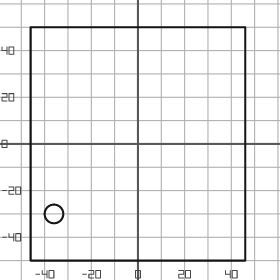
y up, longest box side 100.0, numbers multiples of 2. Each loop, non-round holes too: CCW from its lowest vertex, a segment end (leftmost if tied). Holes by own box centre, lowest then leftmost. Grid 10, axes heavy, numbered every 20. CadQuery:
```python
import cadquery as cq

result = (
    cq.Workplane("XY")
    .moveTo(-46.0, -50.0)
    .lineTo(46.0, -50.0)
    .lineTo(46.0, 50.0)
    .lineTo(-46.0, 50.0)
    .close()
    .moveTo(-36.0, -30.0)
    .circle(4.0)
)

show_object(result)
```